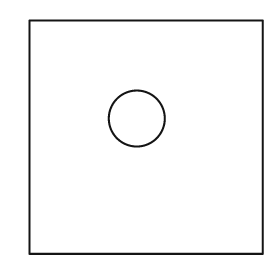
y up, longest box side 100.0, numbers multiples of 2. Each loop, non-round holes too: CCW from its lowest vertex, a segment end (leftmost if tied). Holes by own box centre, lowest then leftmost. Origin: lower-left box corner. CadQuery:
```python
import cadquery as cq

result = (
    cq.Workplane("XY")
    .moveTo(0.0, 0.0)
    .lineTo(100.0, 0.0)
    .lineTo(100.0, 100.0)
    .lineTo(0.0, 100.0)
    .close()
    .moveTo(46.0, 58.0)
    .circle(12.0)
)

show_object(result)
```